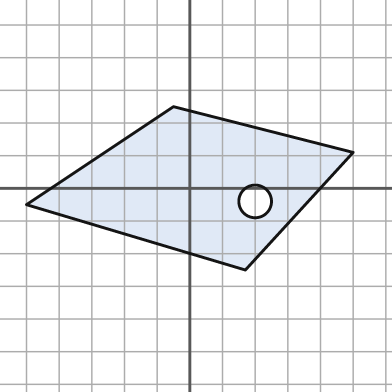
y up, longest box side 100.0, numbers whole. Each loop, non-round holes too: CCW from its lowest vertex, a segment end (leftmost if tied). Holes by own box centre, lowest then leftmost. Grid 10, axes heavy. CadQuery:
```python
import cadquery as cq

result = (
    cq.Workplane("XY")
    .moveTo(17.0, -25.0)
    .lineTo(50.0, 11.0)
    .lineTo(-5.0, 25.0)
    .lineTo(-50.0, -5.0)
    .close()
    .moveTo(20.0, -4.0)
    .circle(5.0)
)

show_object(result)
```